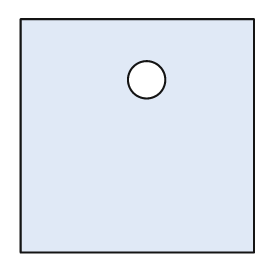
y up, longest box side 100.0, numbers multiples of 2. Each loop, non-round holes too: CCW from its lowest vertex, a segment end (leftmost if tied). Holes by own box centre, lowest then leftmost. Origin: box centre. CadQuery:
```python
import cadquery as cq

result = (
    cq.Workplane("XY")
    .moveTo(-50.0, -50.0)
    .lineTo(50.0, -50.0)
    .lineTo(50.0, 50.0)
    .lineTo(-50.0, 50.0)
    .close()
    .moveTo(4.0, 24.0)
    .circle(8.0)
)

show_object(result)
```